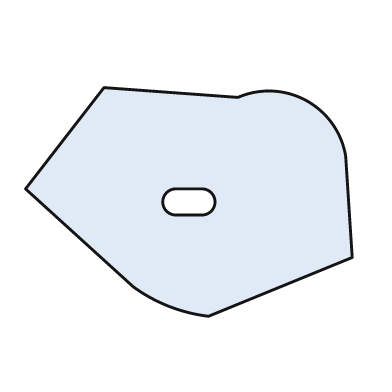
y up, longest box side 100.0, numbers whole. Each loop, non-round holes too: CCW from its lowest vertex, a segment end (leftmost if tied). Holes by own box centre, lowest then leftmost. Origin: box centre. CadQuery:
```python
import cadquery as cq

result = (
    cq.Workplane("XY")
    .moveTo(6.0, -35.0)
    .lineTo(50.0, -17.0)
    .lineTo(48.0, 14.0)
    .threePointArc((36.0, 31.0), (15.0, 32.0))
    .lineTo(-26.0, 35.0)
    .lineTo(-50.0, 4.0)
    .lineTo(-17.0, -26.0)
    .threePointArc((-6.0, -32.0), (6.0, -35.0))
    .close()
    .moveTo(-4.0, -4.0)
    .lineTo(4.0, -4.0)
    .threePointArc((8.0, 0.0), (4.0, 4.0))
    .lineTo(-4.0, 4.0)
    .threePointArc((-8.0, 0.0), (-4.0, -4.0))
    .close()
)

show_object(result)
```